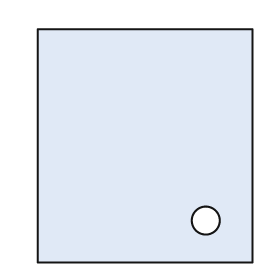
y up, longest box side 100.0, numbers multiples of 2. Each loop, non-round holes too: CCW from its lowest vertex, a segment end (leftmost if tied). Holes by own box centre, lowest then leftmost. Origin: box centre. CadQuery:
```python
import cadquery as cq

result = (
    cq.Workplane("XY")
    .moveTo(-46.0, -50.0)
    .lineTo(46.0, -50.0)
    .lineTo(46.0, 50.0)
    .lineTo(-46.0, 50.0)
    .close()
    .moveTo(26.0, -32.0)
    .circle(6.0)
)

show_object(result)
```